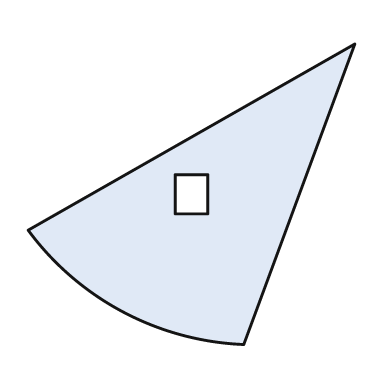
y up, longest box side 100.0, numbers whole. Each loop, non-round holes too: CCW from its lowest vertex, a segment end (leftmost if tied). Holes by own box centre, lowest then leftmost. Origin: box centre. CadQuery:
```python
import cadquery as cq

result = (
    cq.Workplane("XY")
    .moveTo(16.0, -46.0)
    .lineTo(50.0, 46.0)
    .lineTo(-50.0, -11.0)
    .threePointArc((-21.0, -36.0), (16.0, -46.0))
    .close()
    .moveTo(-5.0, -6.0)
    .lineTo(5.0, -6.0)
    .lineTo(5.0, 6.0)
    .lineTo(-5.0, 6.0)
    .close()
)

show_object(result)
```